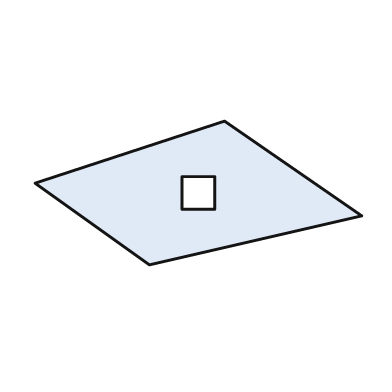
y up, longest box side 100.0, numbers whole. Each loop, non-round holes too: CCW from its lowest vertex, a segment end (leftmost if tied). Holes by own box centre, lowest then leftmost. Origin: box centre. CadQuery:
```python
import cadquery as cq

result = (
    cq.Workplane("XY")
    .moveTo(-15.0, -22.0)
    .lineTo(50.0, -7.0)
    .lineTo(8.0, 22.0)
    .lineTo(-50.0, 3.0)
    .close()
    .moveTo(-5.0, -5.0)
    .lineTo(5.0, -5.0)
    .lineTo(5.0, 5.0)
    .lineTo(-5.0, 5.0)
    .close()
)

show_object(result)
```